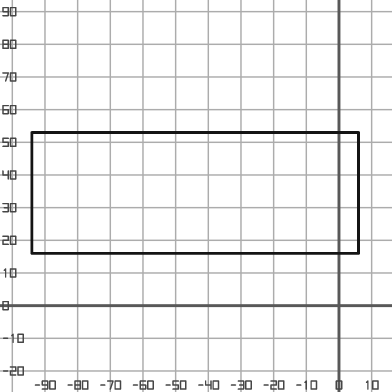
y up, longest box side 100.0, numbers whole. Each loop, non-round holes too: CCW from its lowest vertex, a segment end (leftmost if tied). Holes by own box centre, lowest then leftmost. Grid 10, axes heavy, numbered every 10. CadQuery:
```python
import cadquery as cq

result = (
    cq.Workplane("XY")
    .moveTo(-94.0, 16.0)
    .lineTo(6.0, 16.0)
    .lineTo(6.0, 53.0)
    .lineTo(-94.0, 53.0)
    .close()
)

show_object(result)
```